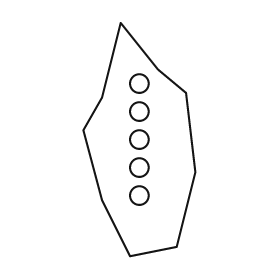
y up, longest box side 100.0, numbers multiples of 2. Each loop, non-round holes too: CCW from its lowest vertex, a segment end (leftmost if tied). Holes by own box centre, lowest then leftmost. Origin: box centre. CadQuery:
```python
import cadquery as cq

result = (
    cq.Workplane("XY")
    .moveTo(-4.0, -50.0)
    .lineTo(16.0, -46.0)
    .lineTo(24.0, -14.0)
    .lineTo(20.0, 20.0)
    .lineTo(8.0, 30.0)
    .lineTo(-8.0, 50.0)
    .lineTo(-16.0, 18.0)
    .lineTo(-24.0, 4.0)
    .lineTo(-16.0, -26.0)
    .close()
    .moveTo(0.0, -24.0)
    .circle(4.0)
    .moveTo(0.0, -12.0)
    .circle(4.0)
    .moveTo(0.0, 0.0)
    .circle(4.0)
    .moveTo(0.0, 12.0)
    .circle(4.0)
    .moveTo(0.0, 24.0)
    .circle(4.0)
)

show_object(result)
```